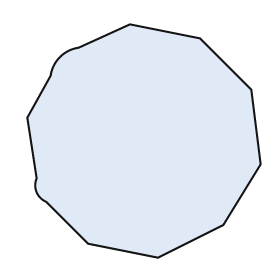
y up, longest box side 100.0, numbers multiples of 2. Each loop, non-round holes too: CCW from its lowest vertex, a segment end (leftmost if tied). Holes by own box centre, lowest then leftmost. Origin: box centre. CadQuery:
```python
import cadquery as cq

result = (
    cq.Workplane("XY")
    .moveTo(6.0, -50.0)
    .lineTo(34.0, -36.0)
    .lineTo(50.0, -10.0)
    .lineTo(46.0, 22.0)
    .lineTo(24.0, 44.0)
    .lineTo(-6.0, 50.0)
    .lineTo(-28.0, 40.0)
    .threePointArc((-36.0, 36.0), (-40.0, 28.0))
    .lineTo(-50.0, 10.0)
    .lineTo(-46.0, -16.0)
    .threePointArc((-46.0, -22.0), (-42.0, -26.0))
    .lineTo(-24.0, -44.0)
    .close()
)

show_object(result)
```